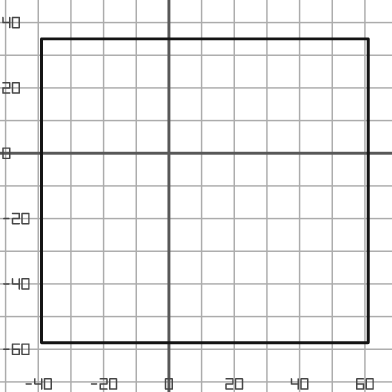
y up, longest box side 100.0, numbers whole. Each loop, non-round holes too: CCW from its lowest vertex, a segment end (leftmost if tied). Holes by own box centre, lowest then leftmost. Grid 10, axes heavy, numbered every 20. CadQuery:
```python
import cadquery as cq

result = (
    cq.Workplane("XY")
    .moveTo(-39.0, -58.0)
    .lineTo(61.0, -58.0)
    .lineTo(61.0, 35.0)
    .lineTo(-39.0, 35.0)
    .close()
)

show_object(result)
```